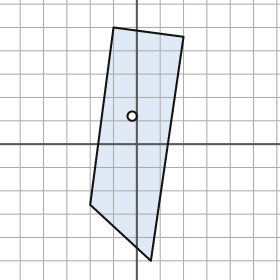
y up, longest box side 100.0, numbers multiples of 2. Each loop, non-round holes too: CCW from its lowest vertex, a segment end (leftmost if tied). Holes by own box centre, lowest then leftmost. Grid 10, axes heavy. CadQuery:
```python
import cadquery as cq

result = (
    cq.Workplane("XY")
    .moveTo(6.0, -50.0)
    .lineTo(20.0, 46.0)
    .lineTo(-10.0, 50.0)
    .lineTo(-20.0, -26.0)
    .close()
    .moveTo(-2.0, 12.0)
    .circle(2.0)
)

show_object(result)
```